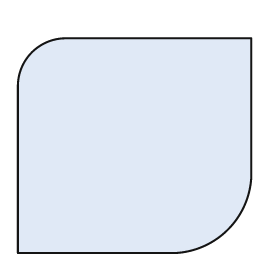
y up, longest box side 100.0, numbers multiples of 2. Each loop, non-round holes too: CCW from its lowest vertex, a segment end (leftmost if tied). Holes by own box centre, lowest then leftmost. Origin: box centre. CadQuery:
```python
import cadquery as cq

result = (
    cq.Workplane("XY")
    .moveTo(-50.0, -46.0)
    .lineTo(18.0, -46.0)
    .threePointArc((40.0, -36.0), (50.0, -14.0))
    .lineTo(50.0, 46.0)
    .lineTo(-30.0, 46.0)
    .threePointArc((-44.0, 40.0), (-50.0, 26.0))
    .close()
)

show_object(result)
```